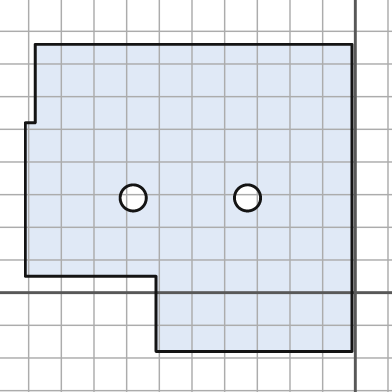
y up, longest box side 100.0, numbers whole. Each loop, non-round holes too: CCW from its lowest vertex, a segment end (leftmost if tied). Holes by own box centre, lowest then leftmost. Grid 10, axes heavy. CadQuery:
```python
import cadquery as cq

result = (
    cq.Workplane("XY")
    .moveTo(-61.0, -18.0)
    .lineTo(-1.0, -18.0)
    .lineTo(-1.0, 76.0)
    .lineTo(-98.0, 76.0)
    .lineTo(-98.0, 52.0)
    .lineTo(-101.0, 52.0)
    .lineTo(-101.0, 5.0)
    .lineTo(-61.0, 5.0)
    .close()
    .moveTo(-68.0, 29.0)
    .circle(4.0)
    .moveTo(-33.0, 29.0)
    .circle(4.0)
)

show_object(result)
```